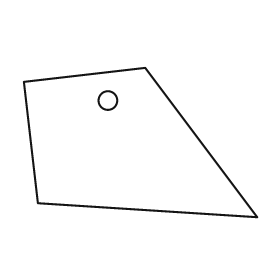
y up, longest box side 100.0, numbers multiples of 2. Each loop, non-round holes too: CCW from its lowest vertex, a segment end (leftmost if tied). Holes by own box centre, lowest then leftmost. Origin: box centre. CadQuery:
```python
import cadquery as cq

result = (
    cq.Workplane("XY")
    .moveTo(50.0, -32.0)
    .lineTo(2.0, 32.0)
    .lineTo(-50.0, 26.0)
    .lineTo(-44.0, -26.0)
    .close()
    .moveTo(-14.0, 18.0)
    .circle(4.0)
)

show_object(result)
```